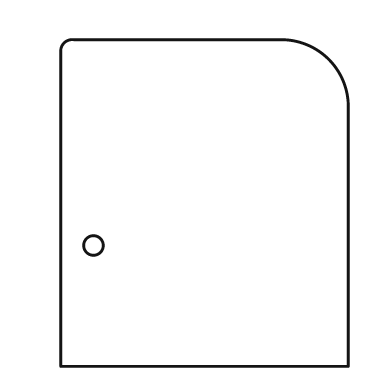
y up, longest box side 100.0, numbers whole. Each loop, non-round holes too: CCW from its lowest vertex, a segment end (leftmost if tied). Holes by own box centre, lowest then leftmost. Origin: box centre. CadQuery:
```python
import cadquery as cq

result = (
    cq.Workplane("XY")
    .moveTo(-44.0, -50.0)
    .lineTo(44.0, -50.0)
    .lineTo(44.0, 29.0)
    .threePointArc((38.0, 44.0), (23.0, 50.0))
    .lineTo(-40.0, 50.0)
    .threePointArc((-43.0, 49.0), (-44.0, 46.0))
    .close()
    .moveTo(-34.0, -13.0)
    .circle(3.0)
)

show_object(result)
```